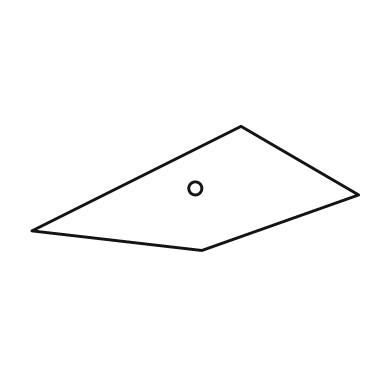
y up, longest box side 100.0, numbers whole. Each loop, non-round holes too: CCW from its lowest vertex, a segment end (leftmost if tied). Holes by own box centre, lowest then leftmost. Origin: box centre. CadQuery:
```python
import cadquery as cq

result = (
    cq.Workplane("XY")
    .moveTo(2.0, -19.0)
    .lineTo(50.0, -2.0)
    .lineTo(14.0, 19.0)
    .lineTo(-50.0, -13.0)
    .close()
    .moveTo(0.0, 0.0)
    .circle(2.0)
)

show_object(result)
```